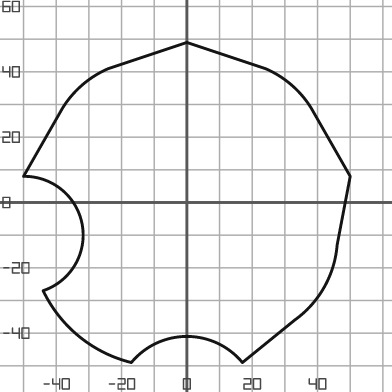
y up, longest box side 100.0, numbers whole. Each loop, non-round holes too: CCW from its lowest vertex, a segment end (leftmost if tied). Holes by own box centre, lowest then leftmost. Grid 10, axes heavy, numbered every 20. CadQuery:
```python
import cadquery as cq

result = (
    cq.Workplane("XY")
    .moveTo(-17.0, -49.0)
    .threePointArc((0.0, -41.0), (17.0, -49.0))
    .lineTo(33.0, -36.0)
    .threePointArc((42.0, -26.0), (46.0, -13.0))
    .lineTo(50.0, 8.0)
    .lineTo(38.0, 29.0)
    .threePointArc((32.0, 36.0), (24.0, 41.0))
    .lineTo(0.0, 49.0)
    .lineTo(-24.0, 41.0)
    .threePointArc((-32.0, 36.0), (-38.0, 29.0))
    .lineTo(-50.0, 8.0)
    .threePointArc((-32.0, -7.0), (-44.0, -27.0))
    .threePointArc((-33.0, -41.0), (-17.0, -49.0))
    .close()
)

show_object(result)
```